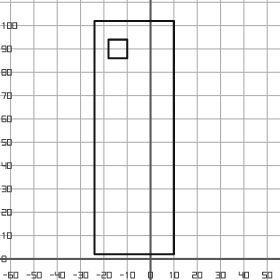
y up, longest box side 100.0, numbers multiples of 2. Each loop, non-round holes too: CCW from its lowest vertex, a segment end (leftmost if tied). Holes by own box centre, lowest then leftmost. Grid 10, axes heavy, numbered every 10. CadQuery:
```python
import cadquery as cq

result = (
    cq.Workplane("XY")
    .moveTo(-24.0, 2.0)
    .lineTo(10.0, 2.0)
    .lineTo(10.0, 102.0)
    .lineTo(-24.0, 102.0)
    .close()
    .moveTo(-18.0, 86.0)
    .lineTo(-10.0, 86.0)
    .lineTo(-10.0, 94.0)
    .lineTo(-18.0, 94.0)
    .close()
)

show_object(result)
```